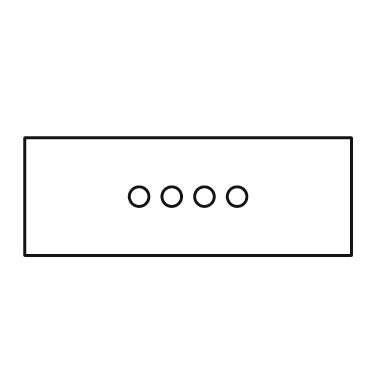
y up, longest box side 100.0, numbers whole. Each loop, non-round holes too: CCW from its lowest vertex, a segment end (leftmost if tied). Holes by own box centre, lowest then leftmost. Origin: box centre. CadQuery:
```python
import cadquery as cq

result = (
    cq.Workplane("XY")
    .moveTo(-50.0, -18.0)
    .lineTo(50.0, -18.0)
    .lineTo(50.0, 18.0)
    .lineTo(-50.0, 18.0)
    .close()
    .moveTo(-15.0, 0.0)
    .circle(3.0)
    .moveTo(-5.0, 0.0)
    .circle(3.0)
    .moveTo(5.0, 0.0)
    .circle(3.0)
    .moveTo(15.0, 0.0)
    .circle(3.0)
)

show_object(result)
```